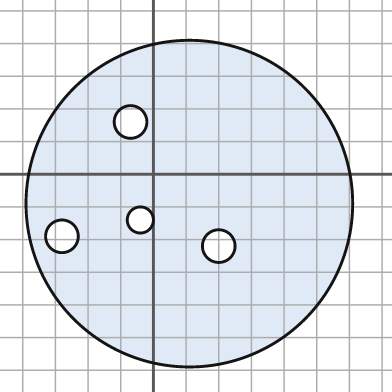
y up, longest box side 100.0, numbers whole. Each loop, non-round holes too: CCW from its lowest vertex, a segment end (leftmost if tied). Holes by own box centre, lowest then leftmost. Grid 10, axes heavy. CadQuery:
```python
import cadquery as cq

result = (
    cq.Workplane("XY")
    .moveTo(11.0, -9.0)
    .circle(50.0)
    .moveTo(20.0, -22.0)
    .circle(5.0)
    .moveTo(-28.0, -19.0)
    .circle(5.0)
    .moveTo(-4.0, -14.0)
    .circle(4.0)
    .moveTo(-7.0, 16.0)
    .circle(5.0)
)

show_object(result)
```